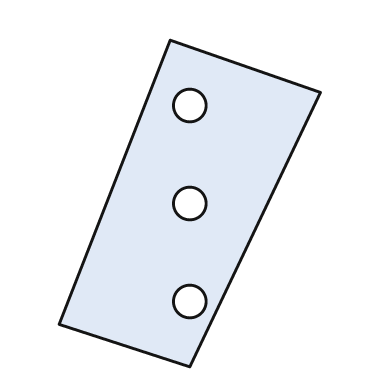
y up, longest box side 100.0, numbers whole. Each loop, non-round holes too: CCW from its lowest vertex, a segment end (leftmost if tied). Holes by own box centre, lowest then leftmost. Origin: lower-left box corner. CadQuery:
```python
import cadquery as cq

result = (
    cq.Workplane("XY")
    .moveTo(40.0, 0.0)
    .lineTo(80.0, 84.0)
    .lineTo(34.0, 100.0)
    .lineTo(0.0, 13.0)
    .close()
    .moveTo(40.0, 20.0)
    .circle(5.0)
    .moveTo(40.0, 50.0)
    .circle(5.0)
    .moveTo(40.0, 80.0)
    .circle(5.0)
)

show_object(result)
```